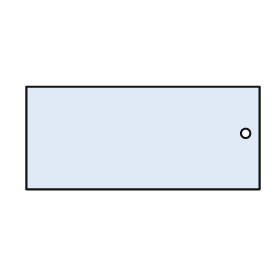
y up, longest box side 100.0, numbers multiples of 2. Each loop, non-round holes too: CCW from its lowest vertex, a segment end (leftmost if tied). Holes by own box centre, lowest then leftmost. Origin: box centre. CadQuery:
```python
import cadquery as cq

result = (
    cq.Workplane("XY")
    .moveTo(-50.0, -22.0)
    .lineTo(50.0, -22.0)
    .lineTo(50.0, 22.0)
    .lineTo(-50.0, 22.0)
    .close()
    .moveTo(44.0, 2.0)
    .circle(2.0)
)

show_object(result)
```